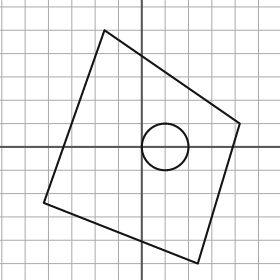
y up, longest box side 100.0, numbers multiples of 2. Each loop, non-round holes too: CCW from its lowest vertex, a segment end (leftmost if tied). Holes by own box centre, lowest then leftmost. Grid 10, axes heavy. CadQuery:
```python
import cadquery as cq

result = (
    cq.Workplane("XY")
    .moveTo(24.0, -50.0)
    .lineTo(42.0, 10.0)
    .lineTo(-16.0, 50.0)
    .lineTo(-42.0, -24.0)
    .close()
    .moveTo(10.0, 0.0)
    .circle(10.0)
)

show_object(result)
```